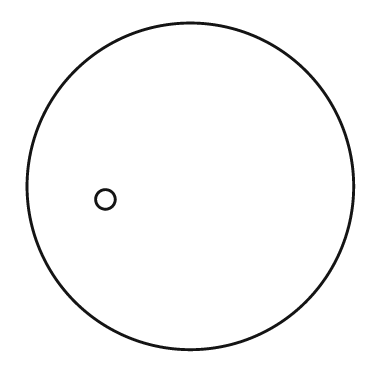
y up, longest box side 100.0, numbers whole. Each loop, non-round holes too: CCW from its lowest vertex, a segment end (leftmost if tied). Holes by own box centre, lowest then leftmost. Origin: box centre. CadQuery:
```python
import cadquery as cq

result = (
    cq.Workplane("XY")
    .moveTo(0.0, 0.0)
    .circle(50.0)
    .moveTo(-26.0, -4.0)
    .circle(3.0)
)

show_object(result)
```